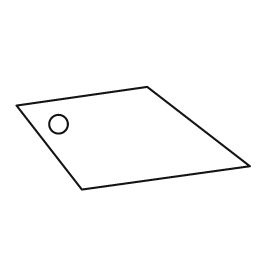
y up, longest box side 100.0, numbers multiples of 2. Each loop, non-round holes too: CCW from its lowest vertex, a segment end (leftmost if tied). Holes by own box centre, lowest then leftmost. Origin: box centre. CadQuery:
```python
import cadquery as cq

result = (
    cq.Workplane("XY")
    .moveTo(-22.0, -22.0)
    .lineTo(50.0, -12.0)
    .lineTo(6.0, 22.0)
    .lineTo(-50.0, 14.0)
    .close()
    .moveTo(-32.0, 6.0)
    .circle(4.0)
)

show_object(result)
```